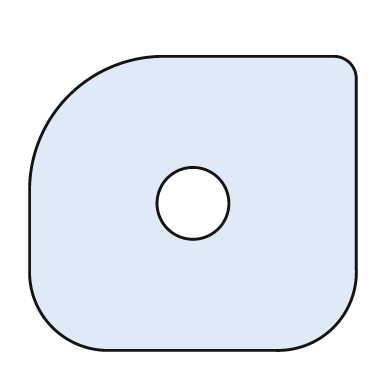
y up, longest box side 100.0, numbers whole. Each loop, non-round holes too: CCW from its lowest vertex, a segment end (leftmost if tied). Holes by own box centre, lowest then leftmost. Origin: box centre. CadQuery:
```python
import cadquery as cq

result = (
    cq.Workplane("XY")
    .moveTo(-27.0, -45.0)
    .lineTo(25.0, -45.0)
    .threePointArc((43.0, -38.0), (50.0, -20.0))
    .lineTo(50.0, 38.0)
    .threePointArc((48.0, 43.0), (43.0, 45.0))
    .lineTo(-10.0, 45.0)
    .threePointArc((-38.0, 33.0), (-50.0, 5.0))
    .lineTo(-50.0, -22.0)
    .threePointArc((-43.0, -38.0), (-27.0, -45.0))
    .close()
    .moveTo(0.0, 0.0)
    .circle(11.0)
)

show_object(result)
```